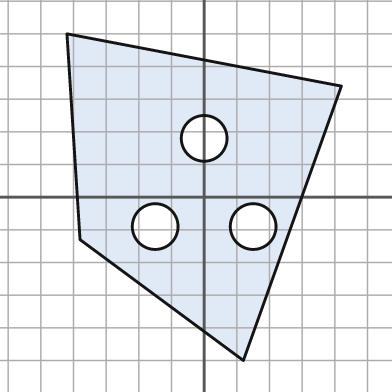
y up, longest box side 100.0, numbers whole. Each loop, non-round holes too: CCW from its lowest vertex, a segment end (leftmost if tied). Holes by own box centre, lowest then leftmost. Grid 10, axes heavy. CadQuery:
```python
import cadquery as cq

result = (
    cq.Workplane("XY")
    .moveTo(12.0, -50.0)
    .lineTo(42.0, 34.0)
    .lineTo(-42.0, 50.0)
    .lineTo(-38.0, -13.0)
    .close()
    .moveTo(-15.0, -9.0)
    .circle(7.0)
    .moveTo(15.0, -9.0)
    .circle(7.0)
    .moveTo(0.0, 18.0)
    .circle(7.0)
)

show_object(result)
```